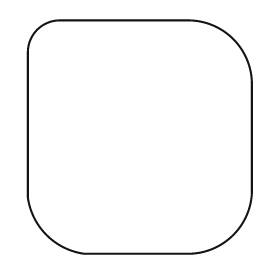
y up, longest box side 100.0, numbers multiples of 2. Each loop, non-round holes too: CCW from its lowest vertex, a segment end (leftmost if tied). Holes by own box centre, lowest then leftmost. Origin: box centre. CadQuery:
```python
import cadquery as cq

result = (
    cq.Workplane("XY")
    .moveTo(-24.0, -50.0)
    .lineTo(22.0, -50.0)
    .threePointArc((40.0, -42.0), (48.0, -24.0))
    .lineTo(48.0, 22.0)
    .threePointArc((40.0, 42.0), (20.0, 50.0))
    .lineTo(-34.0, 50.0)
    .threePointArc((-44.0, 46.0), (-48.0, 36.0))
    .lineTo(-48.0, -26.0)
    .threePointArc((-40.0, -42.0), (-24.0, -50.0))
    .close()
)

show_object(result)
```